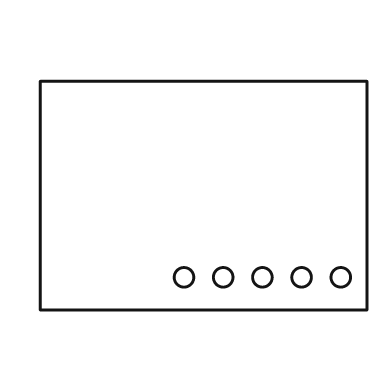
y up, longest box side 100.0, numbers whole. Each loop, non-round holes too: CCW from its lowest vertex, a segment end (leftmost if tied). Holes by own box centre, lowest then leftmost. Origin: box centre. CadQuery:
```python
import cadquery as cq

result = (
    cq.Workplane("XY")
    .moveTo(-50.0, -35.0)
    .lineTo(50.0, -35.0)
    .lineTo(50.0, 35.0)
    .lineTo(-50.0, 35.0)
    .close()
    .moveTo(-6.0, -25.0)
    .circle(3.0)
    .moveTo(6.0, -25.0)
    .circle(3.0)
    .moveTo(18.0, -25.0)
    .circle(3.0)
    .moveTo(30.0, -25.0)
    .circle(3.0)
    .moveTo(42.0, -25.0)
    .circle(3.0)
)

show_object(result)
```